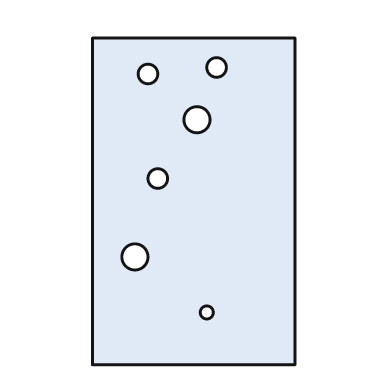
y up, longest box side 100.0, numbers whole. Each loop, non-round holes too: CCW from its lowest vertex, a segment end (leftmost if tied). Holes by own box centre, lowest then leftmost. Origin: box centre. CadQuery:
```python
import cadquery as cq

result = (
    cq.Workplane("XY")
    .moveTo(-31.0, -50.0)
    .lineTo(31.0, -50.0)
    .lineTo(31.0, 50.0)
    .lineTo(-31.0, 50.0)
    .close()
    .moveTo(4.0, -34.0)
    .circle(2.0)
    .moveTo(-18.0, -17.0)
    .circle(4.0)
    .moveTo(-11.0, 7.0)
    .circle(3.0)
    .moveTo(1.0, 25.0)
    .circle(4.0)
    .moveTo(-14.0, 39.0)
    .circle(3.0)
    .moveTo(7.0, 41.0)
    .circle(3.0)
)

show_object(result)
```